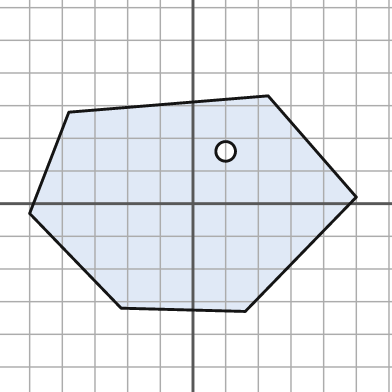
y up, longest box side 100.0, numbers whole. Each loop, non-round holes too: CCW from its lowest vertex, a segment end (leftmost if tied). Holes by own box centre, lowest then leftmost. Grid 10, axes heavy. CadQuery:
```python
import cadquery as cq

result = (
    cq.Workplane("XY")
    .moveTo(16.0, -33.0)
    .lineTo(50.0, 2.0)
    .lineTo(23.0, 33.0)
    .lineTo(-38.0, 28.0)
    .lineTo(-50.0, -3.0)
    .lineTo(-22.0, -32.0)
    .close()
    .moveTo(10.0, 16.0)
    .circle(3.0)
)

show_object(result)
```